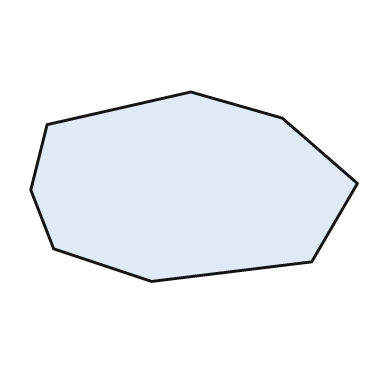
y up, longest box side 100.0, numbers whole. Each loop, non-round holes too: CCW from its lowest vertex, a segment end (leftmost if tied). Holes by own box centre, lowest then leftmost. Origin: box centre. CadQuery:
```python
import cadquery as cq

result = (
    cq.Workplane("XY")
    .moveTo(-13.0, -29.0)
    .lineTo(36.0, -23.0)
    .lineTo(50.0, 1.0)
    .lineTo(27.0, 21.0)
    .lineTo(-1.0, 29.0)
    .lineTo(-45.0, 19.0)
    .lineTo(-50.0, -1.0)
    .lineTo(-43.0, -19.0)
    .close()
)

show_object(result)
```